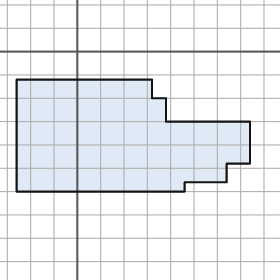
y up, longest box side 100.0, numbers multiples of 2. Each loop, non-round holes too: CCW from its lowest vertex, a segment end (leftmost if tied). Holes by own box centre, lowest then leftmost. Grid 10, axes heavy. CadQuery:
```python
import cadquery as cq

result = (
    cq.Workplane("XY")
    .moveTo(-26.0, -60.0)
    .lineTo(46.0, -60.0)
    .lineTo(46.0, -56.0)
    .lineTo(64.0, -56.0)
    .lineTo(64.0, -48.0)
    .lineTo(74.0, -48.0)
    .lineTo(74.0, -30.0)
    .lineTo(38.0, -30.0)
    .lineTo(38.0, -20.0)
    .lineTo(32.0, -20.0)
    .lineTo(32.0, -12.0)
    .lineTo(-26.0, -12.0)
    .close()
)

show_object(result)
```